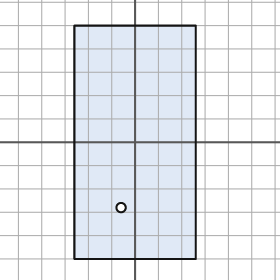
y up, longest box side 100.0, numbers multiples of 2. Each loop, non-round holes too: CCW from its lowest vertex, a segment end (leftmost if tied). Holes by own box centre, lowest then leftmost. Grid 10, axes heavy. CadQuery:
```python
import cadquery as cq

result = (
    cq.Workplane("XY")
    .moveTo(-26.0, -50.0)
    .lineTo(26.0, -50.0)
    .lineTo(26.0, 50.0)
    .lineTo(-26.0, 50.0)
    .close()
    .moveTo(-6.0, -28.0)
    .circle(2.0)
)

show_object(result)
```